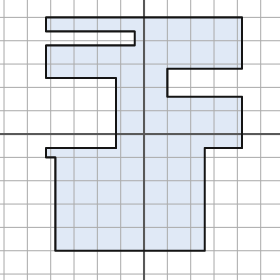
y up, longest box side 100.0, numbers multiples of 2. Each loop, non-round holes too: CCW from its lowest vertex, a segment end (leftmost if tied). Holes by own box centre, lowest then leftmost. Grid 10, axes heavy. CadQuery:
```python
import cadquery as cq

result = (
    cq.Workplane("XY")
    .moveTo(-38.0, -50.0)
    .lineTo(26.0, -50.0)
    .lineTo(26.0, -6.0)
    .lineTo(42.0, -6.0)
    .lineTo(42.0, 16.0)
    .lineTo(10.0, 16.0)
    .lineTo(10.0, 28.0)
    .lineTo(42.0, 28.0)
    .lineTo(42.0, 50.0)
    .lineTo(-42.0, 50.0)
    .lineTo(-42.0, 44.0)
    .lineTo(-4.0, 44.0)
    .lineTo(-4.0, 38.0)
    .lineTo(-42.0, 38.0)
    .lineTo(-42.0, 24.0)
    .lineTo(-12.0, 24.0)
    .lineTo(-12.0, -6.0)
    .lineTo(-42.0, -6.0)
    .lineTo(-42.0, -10.0)
    .lineTo(-38.0, -10.0)
    .close()
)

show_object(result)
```